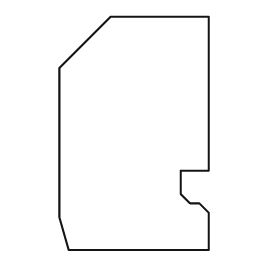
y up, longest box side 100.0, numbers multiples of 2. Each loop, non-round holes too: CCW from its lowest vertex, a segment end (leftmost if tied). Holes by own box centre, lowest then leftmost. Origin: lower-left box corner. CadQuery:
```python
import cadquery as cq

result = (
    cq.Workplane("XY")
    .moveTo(4.0, 0.0)
    .lineTo(64.0, 0.0)
    .lineTo(64.0, 16.0)
    .lineTo(60.0, 20.0)
    .lineTo(56.0, 20.0)
    .lineTo(52.0, 24.0)
    .lineTo(52.0, 34.0)
    .lineTo(64.0, 34.0)
    .lineTo(64.0, 100.0)
    .lineTo(22.0, 100.0)
    .lineTo(0.0, 78.0)
    .lineTo(0.0, 14.0)
    .close()
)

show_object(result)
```